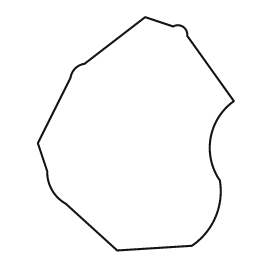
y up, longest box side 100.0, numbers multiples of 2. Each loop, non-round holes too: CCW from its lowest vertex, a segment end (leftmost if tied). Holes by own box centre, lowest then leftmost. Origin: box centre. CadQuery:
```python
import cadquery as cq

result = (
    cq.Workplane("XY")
    .moveTo(-8.0, -50.0)
    .lineTo(24.0, -48.0)
    .threePointArc((34.0, -36.0), (36.0, -20.0))
    .threePointArc((32.0, -2.0), (42.0, 14.0))
    .lineTo(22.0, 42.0)
    .threePointArc((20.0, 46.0), (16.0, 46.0))
    .lineTo(4.0, 50.0)
    .lineTo(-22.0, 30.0)
    .threePointArc((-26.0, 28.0), (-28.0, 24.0))
    .lineTo(-42.0, -4.0)
    .lineTo(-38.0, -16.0)
    .threePointArc((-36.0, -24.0), (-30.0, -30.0))
    .close()
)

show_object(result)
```